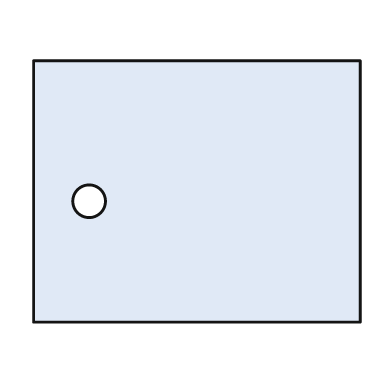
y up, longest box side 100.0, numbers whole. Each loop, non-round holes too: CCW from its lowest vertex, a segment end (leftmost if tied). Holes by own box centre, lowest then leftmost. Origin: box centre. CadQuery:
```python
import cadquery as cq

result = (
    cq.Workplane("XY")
    .moveTo(-50.0, -40.0)
    .lineTo(50.0, -40.0)
    .lineTo(50.0, 40.0)
    .lineTo(-50.0, 40.0)
    .close()
    .moveTo(-33.0, -3.0)
    .circle(5.0)
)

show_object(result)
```